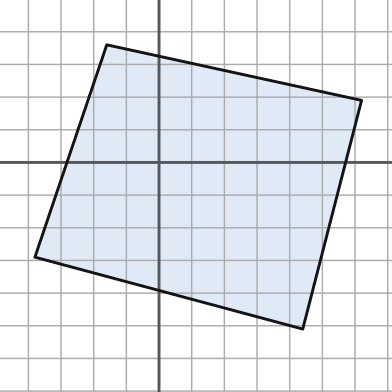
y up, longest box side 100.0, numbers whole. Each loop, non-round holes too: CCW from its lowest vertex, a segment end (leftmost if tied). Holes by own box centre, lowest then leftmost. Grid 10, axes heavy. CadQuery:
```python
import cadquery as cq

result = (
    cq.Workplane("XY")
    .moveTo(44.0, -51.0)
    .lineTo(62.0, 19.0)
    .lineTo(-16.0, 36.0)
    .lineTo(-38.0, -29.0)
    .close()
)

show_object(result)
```